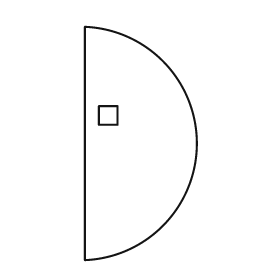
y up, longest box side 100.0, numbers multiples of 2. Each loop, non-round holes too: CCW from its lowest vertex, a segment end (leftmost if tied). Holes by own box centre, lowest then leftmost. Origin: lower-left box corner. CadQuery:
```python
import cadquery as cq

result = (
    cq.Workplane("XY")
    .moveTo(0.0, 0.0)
    .threePointArc((48.0, 50.0), (0.0, 100.0))
    .close()
    .moveTo(6.0, 58.0)
    .lineTo(14.0, 58.0)
    .lineTo(14.0, 66.0)
    .lineTo(6.0, 66.0)
    .close()
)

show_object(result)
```